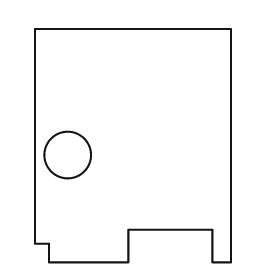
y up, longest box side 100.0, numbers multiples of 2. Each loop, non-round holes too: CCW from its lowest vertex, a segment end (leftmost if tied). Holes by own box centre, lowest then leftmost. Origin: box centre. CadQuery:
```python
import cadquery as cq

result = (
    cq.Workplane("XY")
    .moveTo(-36.0, -50.0)
    .lineTo(-2.0, -50.0)
    .lineTo(-2.0, -36.0)
    .lineTo(34.0, -36.0)
    .lineTo(34.0, -50.0)
    .lineTo(42.0, -50.0)
    .lineTo(42.0, 50.0)
    .lineTo(-42.0, 50.0)
    .lineTo(-42.0, -42.0)
    .lineTo(-36.0, -42.0)
    .close()
    .moveTo(-28.0, -4.0)
    .circle(10.0)
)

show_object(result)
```